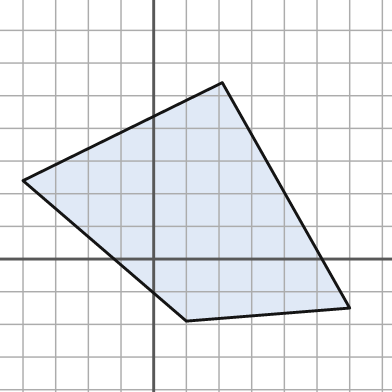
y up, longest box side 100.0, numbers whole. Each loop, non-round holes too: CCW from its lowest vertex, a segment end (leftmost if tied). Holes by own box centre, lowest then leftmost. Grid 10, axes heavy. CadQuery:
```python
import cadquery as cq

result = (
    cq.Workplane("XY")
    .moveTo(10.0, -19.0)
    .lineTo(60.0, -15.0)
    .lineTo(21.0, 54.0)
    .lineTo(-40.0, 24.0)
    .close()
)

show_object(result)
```